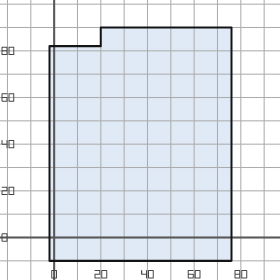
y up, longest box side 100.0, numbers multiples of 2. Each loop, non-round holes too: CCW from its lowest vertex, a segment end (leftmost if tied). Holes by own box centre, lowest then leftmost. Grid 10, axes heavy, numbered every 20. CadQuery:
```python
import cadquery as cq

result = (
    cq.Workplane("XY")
    .moveTo(-2.0, -10.0)
    .lineTo(76.0, -10.0)
    .lineTo(76.0, 90.0)
    .lineTo(20.0, 90.0)
    .lineTo(20.0, 82.0)
    .lineTo(-2.0, 82.0)
    .close()
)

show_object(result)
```